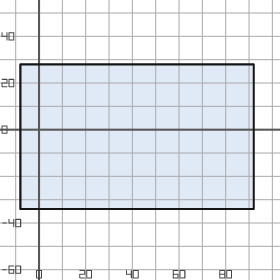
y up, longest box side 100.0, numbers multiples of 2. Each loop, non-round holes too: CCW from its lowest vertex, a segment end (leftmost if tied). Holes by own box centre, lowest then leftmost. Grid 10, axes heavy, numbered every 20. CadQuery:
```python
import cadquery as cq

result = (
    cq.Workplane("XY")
    .moveTo(-8.0, -34.0)
    .lineTo(92.0, -34.0)
    .lineTo(92.0, 28.0)
    .lineTo(-8.0, 28.0)
    .close()
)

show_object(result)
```